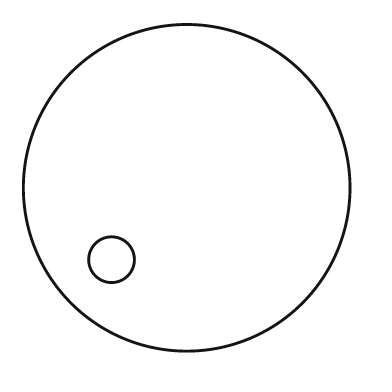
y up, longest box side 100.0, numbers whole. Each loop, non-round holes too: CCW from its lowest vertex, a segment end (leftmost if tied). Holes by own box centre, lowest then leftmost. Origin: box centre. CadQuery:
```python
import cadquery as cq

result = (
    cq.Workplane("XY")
    .moveTo(0.0, 0.0)
    .circle(50.0)
    .moveTo(-23.0, -22.0)
    .circle(7.0)
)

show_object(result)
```